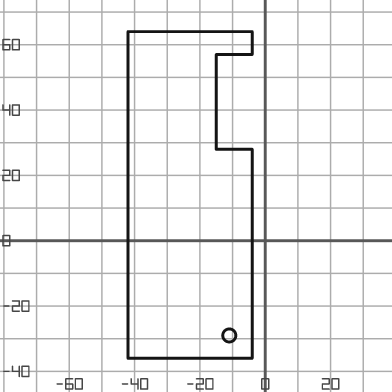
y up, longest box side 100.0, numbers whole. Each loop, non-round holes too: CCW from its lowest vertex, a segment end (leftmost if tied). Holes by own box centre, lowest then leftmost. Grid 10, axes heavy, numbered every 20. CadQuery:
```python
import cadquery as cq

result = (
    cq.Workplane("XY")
    .moveTo(-42.0, -36.0)
    .lineTo(-4.0, -36.0)
    .lineTo(-4.0, 28.0)
    .lineTo(-15.0, 28.0)
    .lineTo(-15.0, 57.0)
    .lineTo(-4.0, 57.0)
    .lineTo(-4.0, 64.0)
    .lineTo(-42.0, 64.0)
    .close()
    .moveTo(-11.0, -29.0)
    .circle(2.0)
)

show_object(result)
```